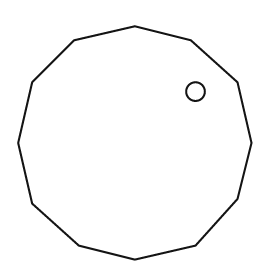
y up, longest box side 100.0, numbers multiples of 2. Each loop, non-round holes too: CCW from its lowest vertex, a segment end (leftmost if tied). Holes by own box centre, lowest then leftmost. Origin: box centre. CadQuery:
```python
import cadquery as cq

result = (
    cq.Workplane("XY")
    .moveTo(0.0, -50.0)
    .lineTo(26.0, -44.0)
    .lineTo(44.0, -24.0)
    .lineTo(50.0, 0.0)
    .lineTo(44.0, 26.0)
    .lineTo(24.0, 44.0)
    .lineTo(0.0, 50.0)
    .lineTo(-26.0, 44.0)
    .lineTo(-44.0, 26.0)
    .lineTo(-50.0, 0.0)
    .lineTo(-44.0, -26.0)
    .lineTo(-24.0, -44.0)
    .close()
    .moveTo(26.0, 22.0)
    .circle(4.0)
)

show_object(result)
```